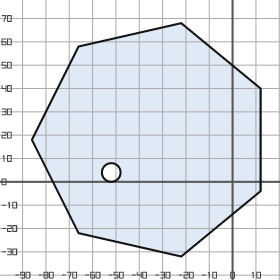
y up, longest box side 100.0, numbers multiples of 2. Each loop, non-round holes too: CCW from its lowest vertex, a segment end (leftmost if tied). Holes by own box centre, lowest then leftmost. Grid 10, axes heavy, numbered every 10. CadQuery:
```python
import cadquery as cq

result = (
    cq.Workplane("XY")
    .moveTo(-22.0, -32.0)
    .lineTo(12.0, -4.0)
    .lineTo(12.0, 40.0)
    .lineTo(-22.0, 68.0)
    .lineTo(-66.0, 58.0)
    .lineTo(-86.0, 18.0)
    .lineTo(-66.0, -22.0)
    .close()
    .moveTo(-52.0, 4.0)
    .circle(4.0)
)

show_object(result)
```